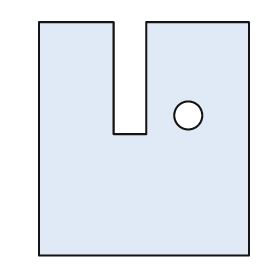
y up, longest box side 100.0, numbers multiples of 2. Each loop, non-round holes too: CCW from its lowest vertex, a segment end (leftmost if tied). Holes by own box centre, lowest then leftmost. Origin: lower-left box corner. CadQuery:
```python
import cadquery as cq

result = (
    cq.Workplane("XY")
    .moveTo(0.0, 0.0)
    .lineTo(90.0, 0.0)
    .lineTo(90.0, 100.0)
    .lineTo(46.0, 100.0)
    .lineTo(46.0, 52.0)
    .lineTo(32.0, 52.0)
    .lineTo(32.0, 100.0)
    .lineTo(0.0, 100.0)
    .close()
    .moveTo(64.0, 60.0)
    .circle(6.0)
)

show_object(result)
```